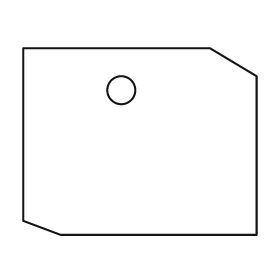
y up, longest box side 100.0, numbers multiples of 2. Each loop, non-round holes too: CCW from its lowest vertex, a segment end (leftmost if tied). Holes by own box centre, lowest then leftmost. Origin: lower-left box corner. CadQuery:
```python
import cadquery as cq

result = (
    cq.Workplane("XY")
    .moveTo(16.0, 0.0)
    .lineTo(100.0, 0.0)
    .lineTo(100.0, 68.0)
    .lineTo(80.0, 80.0)
    .lineTo(0.0, 80.0)
    .lineTo(0.0, 6.0)
    .close()
    .moveTo(42.0, 62.0)
    .circle(6.0)
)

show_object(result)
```